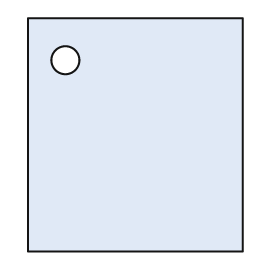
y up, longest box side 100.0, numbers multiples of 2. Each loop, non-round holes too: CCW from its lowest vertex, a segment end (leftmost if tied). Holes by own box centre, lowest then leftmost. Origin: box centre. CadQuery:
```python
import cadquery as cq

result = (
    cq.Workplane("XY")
    .moveTo(-46.0, -50.0)
    .lineTo(46.0, -50.0)
    .lineTo(46.0, 50.0)
    .lineTo(-46.0, 50.0)
    .close()
    .moveTo(-30.0, 32.0)
    .circle(6.0)
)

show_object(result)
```